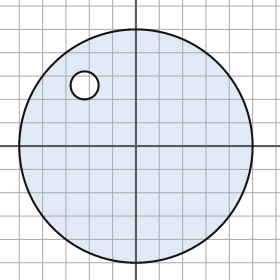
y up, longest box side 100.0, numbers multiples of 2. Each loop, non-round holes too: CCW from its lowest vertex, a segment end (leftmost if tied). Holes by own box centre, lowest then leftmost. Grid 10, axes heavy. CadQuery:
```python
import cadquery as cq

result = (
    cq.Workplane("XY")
    .moveTo(0.0, 0.0)
    .circle(50.0)
    .moveTo(-22.0, 26.0)
    .circle(6.0)
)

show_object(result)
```